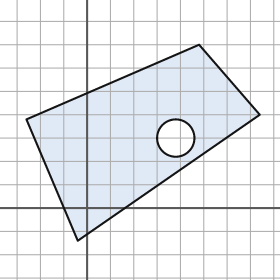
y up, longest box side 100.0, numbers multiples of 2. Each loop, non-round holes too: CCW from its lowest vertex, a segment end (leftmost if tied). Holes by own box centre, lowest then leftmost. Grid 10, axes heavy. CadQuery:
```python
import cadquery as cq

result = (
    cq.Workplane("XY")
    .moveTo(-4.0, -14.0)
    .lineTo(74.0, 40.0)
    .lineTo(48.0, 70.0)
    .lineTo(-26.0, 38.0)
    .close()
    .moveTo(38.0, 30.0)
    .circle(8.0)
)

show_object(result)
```